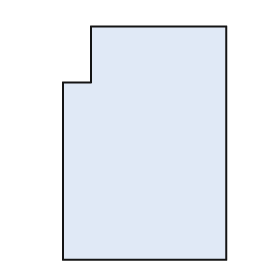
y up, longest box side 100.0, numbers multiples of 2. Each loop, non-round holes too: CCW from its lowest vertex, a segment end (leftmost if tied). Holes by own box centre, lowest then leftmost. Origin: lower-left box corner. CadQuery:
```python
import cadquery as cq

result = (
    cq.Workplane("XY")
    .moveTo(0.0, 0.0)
    .lineTo(70.0, 0.0)
    .lineTo(70.0, 100.0)
    .lineTo(12.0, 100.0)
    .lineTo(12.0, 76.0)
    .lineTo(0.0, 76.0)
    .close()
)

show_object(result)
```